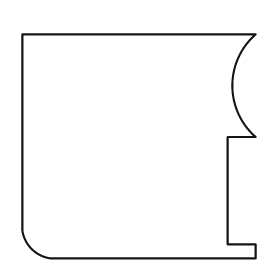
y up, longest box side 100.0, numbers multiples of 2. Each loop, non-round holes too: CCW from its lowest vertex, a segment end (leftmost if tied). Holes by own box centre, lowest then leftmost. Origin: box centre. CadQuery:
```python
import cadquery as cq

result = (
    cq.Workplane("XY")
    .moveTo(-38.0, -48.0)
    .lineTo(50.0, -48.0)
    .lineTo(50.0, -42.0)
    .lineTo(38.0, -42.0)
    .lineTo(38.0, 4.0)
    .lineTo(50.0, 4.0)
    .threePointArc((40.0, 26.0), (50.0, 48.0))
    .lineTo(-50.0, 48.0)
    .lineTo(-50.0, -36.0)
    .threePointArc((-46.0, -44.0), (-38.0, -48.0))
    .close()
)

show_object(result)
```